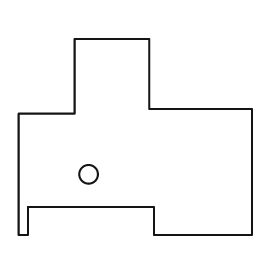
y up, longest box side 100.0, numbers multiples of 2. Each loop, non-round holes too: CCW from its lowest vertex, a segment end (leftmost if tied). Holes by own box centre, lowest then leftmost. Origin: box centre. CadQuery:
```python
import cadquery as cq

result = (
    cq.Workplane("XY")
    .moveTo(-50.0, -42.0)
    .lineTo(-46.0, -42.0)
    .lineTo(-46.0, -30.0)
    .lineTo(8.0, -30.0)
    .lineTo(8.0, -42.0)
    .lineTo(50.0, -42.0)
    .lineTo(50.0, 12.0)
    .lineTo(6.0, 12.0)
    .lineTo(6.0, 42.0)
    .lineTo(-26.0, 42.0)
    .lineTo(-26.0, 10.0)
    .lineTo(-50.0, 10.0)
    .close()
    .moveTo(-20.0, -16.0)
    .circle(4.0)
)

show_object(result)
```